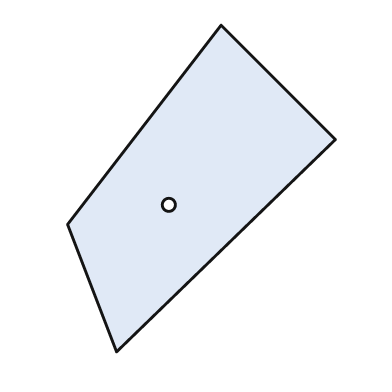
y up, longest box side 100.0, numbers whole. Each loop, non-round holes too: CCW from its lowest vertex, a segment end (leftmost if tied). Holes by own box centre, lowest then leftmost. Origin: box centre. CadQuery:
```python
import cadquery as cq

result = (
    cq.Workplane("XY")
    .moveTo(-26.0, -50.0)
    .lineTo(41.0, 15.0)
    .lineTo(6.0, 50.0)
    .lineTo(-41.0, -11.0)
    .close()
    .moveTo(-10.0, -5.0)
    .circle(2.0)
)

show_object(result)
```